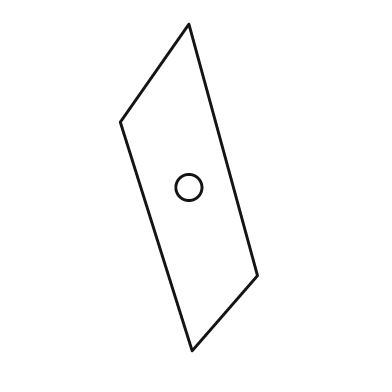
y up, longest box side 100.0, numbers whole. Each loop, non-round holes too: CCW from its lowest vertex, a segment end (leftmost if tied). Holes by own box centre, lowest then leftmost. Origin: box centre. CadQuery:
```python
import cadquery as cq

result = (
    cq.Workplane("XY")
    .moveTo(1.0, -50.0)
    .lineTo(21.0, -27.0)
    .lineTo(0.0, 50.0)
    .lineTo(-21.0, 20.0)
    .close()
    .moveTo(0.0, 0.0)
    .circle(4.0)
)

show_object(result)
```